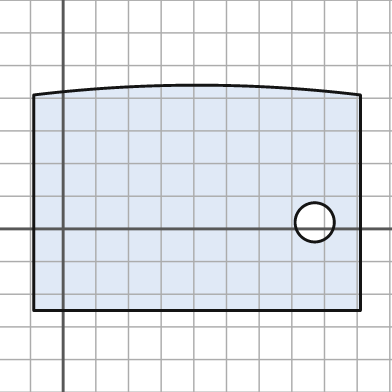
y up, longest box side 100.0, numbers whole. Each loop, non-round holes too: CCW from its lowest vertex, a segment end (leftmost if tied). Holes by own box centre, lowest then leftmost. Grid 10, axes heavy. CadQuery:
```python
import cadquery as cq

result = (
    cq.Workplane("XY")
    .moveTo(-9.0, -25.0)
    .lineTo(91.0, -25.0)
    .lineTo(91.0, 41.0)
    .threePointArc((41.0, 44.0), (-9.0, 41.0))
    .close()
    .moveTo(77.0, 2.0)
    .circle(6.0)
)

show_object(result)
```